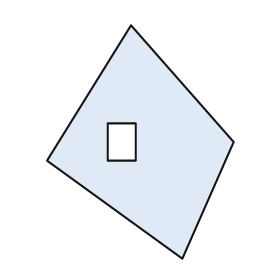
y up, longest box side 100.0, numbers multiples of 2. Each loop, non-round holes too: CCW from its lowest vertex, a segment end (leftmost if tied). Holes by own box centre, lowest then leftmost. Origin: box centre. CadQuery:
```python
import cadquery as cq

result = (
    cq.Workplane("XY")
    .moveTo(18.0, -50.0)
    .lineTo(40.0, 0.0)
    .lineTo(-4.0, 50.0)
    .lineTo(-40.0, -8.0)
    .close()
    .moveTo(-14.0, -8.0)
    .lineTo(-2.0, -8.0)
    .lineTo(-2.0, 8.0)
    .lineTo(-14.0, 8.0)
    .close()
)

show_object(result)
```